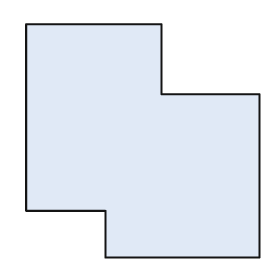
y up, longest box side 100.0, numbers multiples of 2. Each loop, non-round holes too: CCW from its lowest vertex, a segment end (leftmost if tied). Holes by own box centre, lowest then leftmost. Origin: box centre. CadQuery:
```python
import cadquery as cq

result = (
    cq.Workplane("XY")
    .moveTo(-16.0, -50.0)
    .lineTo(50.0, -50.0)
    .lineTo(50.0, 20.0)
    .lineTo(8.0, 20.0)
    .lineTo(8.0, 50.0)
    .lineTo(-50.0, 50.0)
    .lineTo(-50.0, -30.0)
    .lineTo(-16.0, -30.0)
    .close()
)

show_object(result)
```